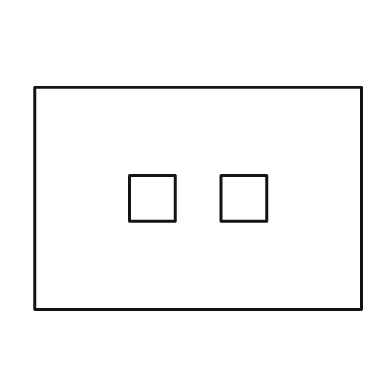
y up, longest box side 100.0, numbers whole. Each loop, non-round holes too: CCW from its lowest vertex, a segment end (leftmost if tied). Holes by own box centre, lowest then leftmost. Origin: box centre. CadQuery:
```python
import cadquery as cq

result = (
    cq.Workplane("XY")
    .moveTo(-50.0, -34.0)
    .lineTo(50.0, -34.0)
    .lineTo(50.0, 34.0)
    .lineTo(-50.0, 34.0)
    .close()
    .moveTo(-21.0, -7.0)
    .lineTo(-7.0, -7.0)
    .lineTo(-7.0, 7.0)
    .lineTo(-21.0, 7.0)
    .close()
    .moveTo(7.0, -7.0)
    .lineTo(21.0, -7.0)
    .lineTo(21.0, 7.0)
    .lineTo(7.0, 7.0)
    .close()
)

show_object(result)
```